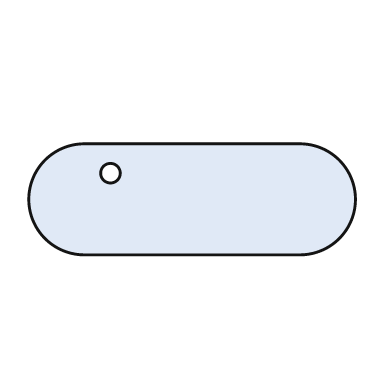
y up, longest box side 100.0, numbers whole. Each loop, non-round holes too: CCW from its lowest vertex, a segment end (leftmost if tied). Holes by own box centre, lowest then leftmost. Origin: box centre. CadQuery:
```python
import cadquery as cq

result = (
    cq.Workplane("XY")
    .moveTo(-33.0, -17.0)
    .lineTo(33.0, -17.0)
    .threePointArc((50.0, 0.0), (33.0, 17.0))
    .lineTo(-33.0, 17.0)
    .threePointArc((-50.0, 0.0), (-33.0, -17.0))
    .close()
    .moveTo(-25.0, 8.0)
    .circle(3.0)
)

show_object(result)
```